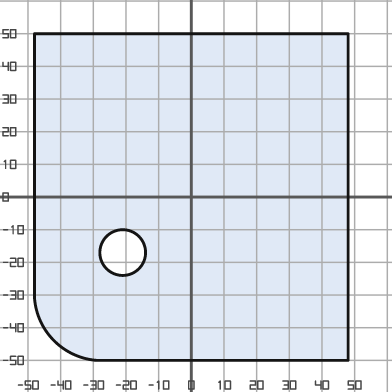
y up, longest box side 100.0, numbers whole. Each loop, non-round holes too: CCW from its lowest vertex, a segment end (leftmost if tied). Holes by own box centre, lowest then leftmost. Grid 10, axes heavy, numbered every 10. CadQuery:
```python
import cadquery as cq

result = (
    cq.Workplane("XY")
    .moveTo(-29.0, -50.0)
    .lineTo(48.0, -50.0)
    .lineTo(48.0, 50.0)
    .lineTo(-48.0, 50.0)
    .lineTo(-48.0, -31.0)
    .threePointArc((-42.0, -44.0), (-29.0, -50.0))
    .close()
    .moveTo(-21.0, -17.0)
    .circle(7.0)
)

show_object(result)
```